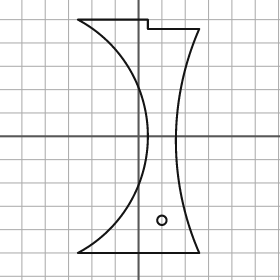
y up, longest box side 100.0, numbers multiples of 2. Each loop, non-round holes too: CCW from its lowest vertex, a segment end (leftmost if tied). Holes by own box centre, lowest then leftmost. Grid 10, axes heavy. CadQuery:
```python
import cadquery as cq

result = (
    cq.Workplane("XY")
    .moveTo(-26.0, -50.0)
    .lineTo(26.0, -50.0)
    .threePointArc((16.0, -2.0), (26.0, 46.0))
    .lineTo(4.0, 46.0)
    .lineTo(4.0, 50.0)
    .lineTo(-26.0, 50.0)
    .threePointArc((4.0, 0.0), (-26.0, -50.0))
    .close()
    .moveTo(10.0, -36.0)
    .circle(2.0)
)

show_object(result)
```